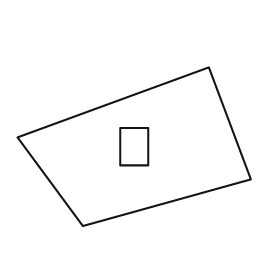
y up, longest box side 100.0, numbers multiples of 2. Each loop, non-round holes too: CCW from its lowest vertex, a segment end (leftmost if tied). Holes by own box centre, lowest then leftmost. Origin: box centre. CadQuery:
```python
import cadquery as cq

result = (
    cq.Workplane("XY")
    .moveTo(-22.0, -34.0)
    .lineTo(50.0, -14.0)
    .lineTo(32.0, 34.0)
    .lineTo(-50.0, 4.0)
    .close()
    .moveTo(-6.0, -8.0)
    .lineTo(6.0, -8.0)
    .lineTo(6.0, 8.0)
    .lineTo(-6.0, 8.0)
    .close()
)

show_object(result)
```